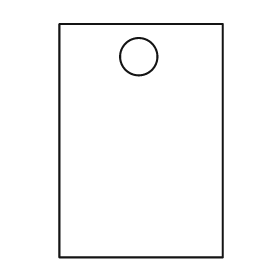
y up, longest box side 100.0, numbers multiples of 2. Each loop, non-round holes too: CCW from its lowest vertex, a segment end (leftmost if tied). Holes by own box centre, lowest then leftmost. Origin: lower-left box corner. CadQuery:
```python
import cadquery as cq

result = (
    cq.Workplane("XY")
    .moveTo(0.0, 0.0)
    .lineTo(70.0, 0.0)
    .lineTo(70.0, 100.0)
    .lineTo(0.0, 100.0)
    .close()
    .moveTo(34.0, 86.0)
    .circle(8.0)
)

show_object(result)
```